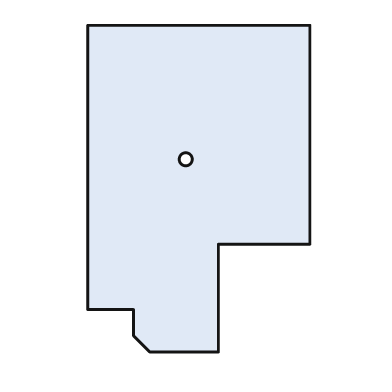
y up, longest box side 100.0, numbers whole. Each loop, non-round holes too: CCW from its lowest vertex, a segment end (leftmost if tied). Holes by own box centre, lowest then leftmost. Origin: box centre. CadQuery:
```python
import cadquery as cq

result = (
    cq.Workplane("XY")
    .moveTo(-15.0, -50.0)
    .lineTo(6.0, -50.0)
    .lineTo(6.0, -17.0)
    .lineTo(34.0, -17.0)
    .lineTo(34.0, 50.0)
    .lineTo(-34.0, 50.0)
    .lineTo(-34.0, -37.0)
    .lineTo(-20.0, -37.0)
    .lineTo(-20.0, -45.0)
    .close()
    .moveTo(-4.0, 9.0)
    .circle(2.0)
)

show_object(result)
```